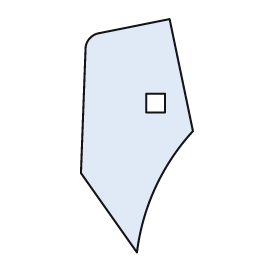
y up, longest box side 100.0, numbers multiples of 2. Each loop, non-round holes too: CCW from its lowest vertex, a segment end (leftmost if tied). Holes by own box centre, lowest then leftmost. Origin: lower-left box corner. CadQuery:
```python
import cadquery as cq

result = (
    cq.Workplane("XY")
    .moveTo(24.0, 0.0)
    .threePointArc((32.0, 28.0), (48.0, 52.0))
    .lineTo(38.0, 100.0)
    .lineTo(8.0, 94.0)
    .threePointArc((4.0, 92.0), (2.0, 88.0))
    .lineTo(0.0, 34.0)
    .close()
    .moveTo(28.0, 60.0)
    .lineTo(36.0, 60.0)
    .lineTo(36.0, 68.0)
    .lineTo(28.0, 68.0)
    .close()
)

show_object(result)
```